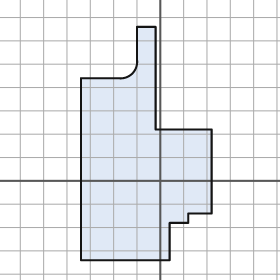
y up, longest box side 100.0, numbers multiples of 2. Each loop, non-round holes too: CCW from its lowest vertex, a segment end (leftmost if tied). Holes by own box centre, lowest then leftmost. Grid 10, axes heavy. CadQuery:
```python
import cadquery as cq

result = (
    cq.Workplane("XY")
    .moveTo(-34.0, -34.0)
    .lineTo(4.0, -34.0)
    .lineTo(4.0, -18.0)
    .lineTo(12.0, -18.0)
    .lineTo(12.0, -14.0)
    .lineTo(22.0, -14.0)
    .lineTo(22.0, 22.0)
    .lineTo(-2.0, 22.0)
    .lineTo(-2.0, 66.0)
    .lineTo(-10.0, 66.0)
    .lineTo(-10.0, 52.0)
    .threePointArc((-12.0, 46.0), (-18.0, 44.0))
    .lineTo(-34.0, 44.0)
    .close()
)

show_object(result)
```